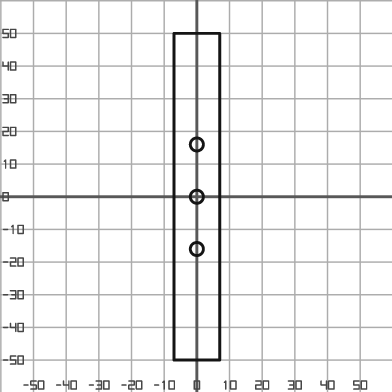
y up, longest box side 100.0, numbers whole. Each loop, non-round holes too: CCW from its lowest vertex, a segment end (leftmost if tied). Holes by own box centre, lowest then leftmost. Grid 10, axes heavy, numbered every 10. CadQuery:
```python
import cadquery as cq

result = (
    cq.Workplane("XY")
    .moveTo(-7.0, -50.0)
    .lineTo(7.0, -50.0)
    .lineTo(7.0, 50.0)
    .lineTo(-7.0, 50.0)
    .close()
    .moveTo(0.0, -16.0)
    .circle(2.0)
    .moveTo(0.0, 0.0)
    .circle(2.0)
    .moveTo(0.0, 16.0)
    .circle(2.0)
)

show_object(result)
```